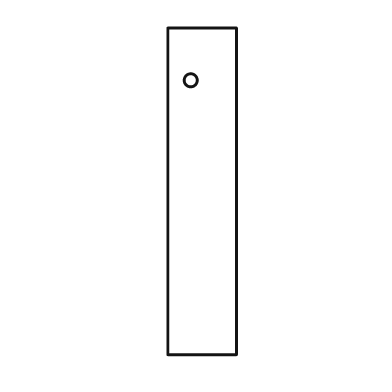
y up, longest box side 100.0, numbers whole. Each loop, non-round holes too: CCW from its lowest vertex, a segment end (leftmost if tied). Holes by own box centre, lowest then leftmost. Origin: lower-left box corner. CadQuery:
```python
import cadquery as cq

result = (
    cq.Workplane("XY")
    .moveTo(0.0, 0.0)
    .lineTo(21.0, 0.0)
    .lineTo(21.0, 100.0)
    .lineTo(0.0, 100.0)
    .close()
    .moveTo(7.0, 84.0)
    .circle(2.0)
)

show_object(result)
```